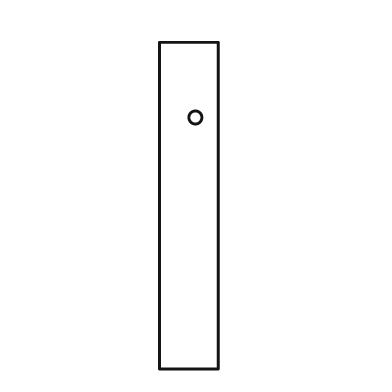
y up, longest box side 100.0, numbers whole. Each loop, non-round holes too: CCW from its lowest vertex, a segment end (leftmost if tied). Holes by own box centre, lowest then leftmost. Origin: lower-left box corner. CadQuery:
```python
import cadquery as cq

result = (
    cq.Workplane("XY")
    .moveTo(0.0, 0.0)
    .lineTo(18.0, 0.0)
    .lineTo(18.0, 100.0)
    .lineTo(0.0, 100.0)
    .close()
    .moveTo(11.0, 77.0)
    .circle(2.0)
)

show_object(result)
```